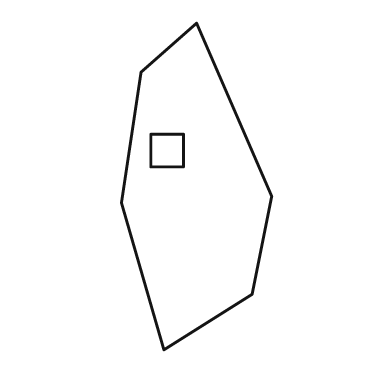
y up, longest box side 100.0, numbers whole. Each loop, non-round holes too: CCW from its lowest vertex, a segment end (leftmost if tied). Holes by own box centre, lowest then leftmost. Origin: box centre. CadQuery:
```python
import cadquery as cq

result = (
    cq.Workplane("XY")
    .moveTo(-10.0, -50.0)
    .lineTo(17.0, -33.0)
    .lineTo(23.0, -3.0)
    .lineTo(0.0, 50.0)
    .lineTo(-17.0, 35.0)
    .lineTo(-23.0, -5.0)
    .close()
    .moveTo(-14.0, 6.0)
    .lineTo(-4.0, 6.0)
    .lineTo(-4.0, 16.0)
    .lineTo(-14.0, 16.0)
    .close()
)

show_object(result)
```